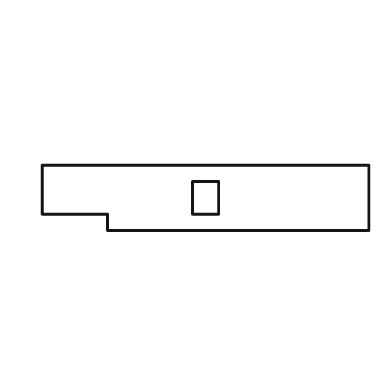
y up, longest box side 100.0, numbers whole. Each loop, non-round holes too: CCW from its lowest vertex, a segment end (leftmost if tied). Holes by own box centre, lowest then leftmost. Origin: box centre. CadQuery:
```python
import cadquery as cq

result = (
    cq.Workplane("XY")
    .moveTo(-30.0, -10.0)
    .lineTo(50.0, -10.0)
    .lineTo(50.0, 10.0)
    .lineTo(-50.0, 10.0)
    .lineTo(-50.0, -5.0)
    .lineTo(-30.0, -5.0)
    .close()
    .moveTo(-4.0, -5.0)
    .lineTo(4.0, -5.0)
    .lineTo(4.0, 5.0)
    .lineTo(-4.0, 5.0)
    .close()
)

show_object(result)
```